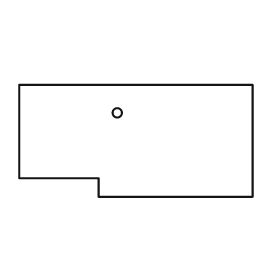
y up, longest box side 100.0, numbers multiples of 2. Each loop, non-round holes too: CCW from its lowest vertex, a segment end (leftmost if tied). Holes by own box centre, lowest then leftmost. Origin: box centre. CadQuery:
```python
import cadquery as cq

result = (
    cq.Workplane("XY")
    .moveTo(-16.0, -24.0)
    .lineTo(50.0, -24.0)
    .lineTo(50.0, 24.0)
    .lineTo(-50.0, 24.0)
    .lineTo(-50.0, -16.0)
    .lineTo(-16.0, -16.0)
    .close()
    .moveTo(-8.0, 12.0)
    .circle(2.0)
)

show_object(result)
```